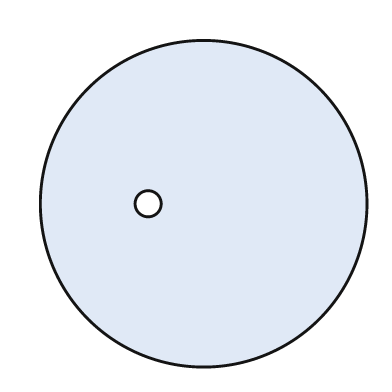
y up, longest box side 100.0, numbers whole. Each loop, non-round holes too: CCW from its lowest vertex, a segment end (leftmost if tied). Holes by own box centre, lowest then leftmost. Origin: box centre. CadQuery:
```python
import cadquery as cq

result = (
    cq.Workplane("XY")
    .moveTo(0.0, 0.0)
    .circle(50.0)
    .moveTo(-17.0, 0.0)
    .circle(4.0)
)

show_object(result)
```